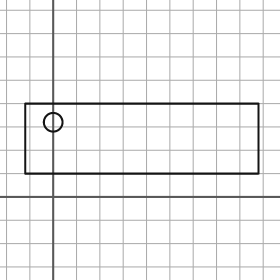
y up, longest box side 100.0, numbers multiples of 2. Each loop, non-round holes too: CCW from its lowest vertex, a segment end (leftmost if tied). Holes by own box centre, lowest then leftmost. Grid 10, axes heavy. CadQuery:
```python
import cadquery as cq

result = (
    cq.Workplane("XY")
    .moveTo(-12.0, 10.0)
    .lineTo(88.0, 10.0)
    .lineTo(88.0, 40.0)
    .lineTo(-12.0, 40.0)
    .close()
    .moveTo(0.0, 32.0)
    .circle(4.0)
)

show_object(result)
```